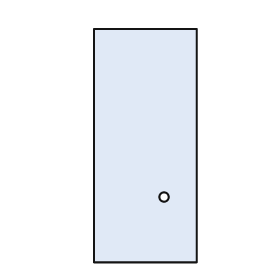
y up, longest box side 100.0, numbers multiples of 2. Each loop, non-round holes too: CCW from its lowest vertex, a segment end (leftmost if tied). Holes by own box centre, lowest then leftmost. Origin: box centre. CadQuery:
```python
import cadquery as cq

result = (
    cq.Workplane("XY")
    .moveTo(-22.0, -50.0)
    .lineTo(22.0, -50.0)
    .lineTo(22.0, 50.0)
    .lineTo(-22.0, 50.0)
    .close()
    .moveTo(8.0, -22.0)
    .circle(2.0)
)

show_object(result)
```